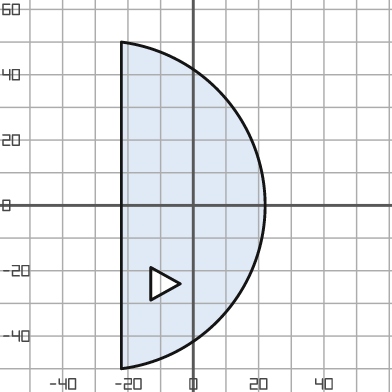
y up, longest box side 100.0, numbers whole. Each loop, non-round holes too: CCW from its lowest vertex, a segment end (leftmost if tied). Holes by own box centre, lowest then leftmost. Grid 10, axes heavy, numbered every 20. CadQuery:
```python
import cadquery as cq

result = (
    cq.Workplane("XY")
    .moveTo(-22.0, -50.0)
    .threePointArc((22.0, 0.0), (-22.0, 50.0))
    .close()
    .moveTo(-13.0, -29.0)
    .lineTo(-4.0, -24.0)
    .lineTo(-13.0, -19.0)
    .close()
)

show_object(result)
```